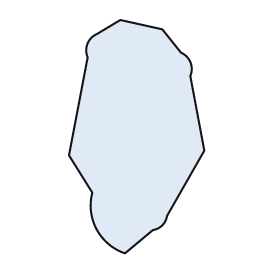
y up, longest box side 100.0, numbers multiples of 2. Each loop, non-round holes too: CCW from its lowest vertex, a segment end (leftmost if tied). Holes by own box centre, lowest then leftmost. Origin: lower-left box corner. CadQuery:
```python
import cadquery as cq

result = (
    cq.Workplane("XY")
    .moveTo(24.0, 0.0)
    .lineTo(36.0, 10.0)
    .threePointArc((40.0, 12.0), (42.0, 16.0))
    .lineTo(58.0, 44.0)
    .lineTo(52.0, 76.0)
    .threePointArc((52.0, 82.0), (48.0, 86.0))
    .lineTo(40.0, 96.0)
    .lineTo(22.0, 100.0)
    .lineTo(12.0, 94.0)
    .threePointArc((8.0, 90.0), (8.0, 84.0))
    .lineTo(0.0, 42.0)
    .lineTo(10.0, 26.0)
    .threePointArc((12.0, 10.0), (24.0, 0.0))
    .close()
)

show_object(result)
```